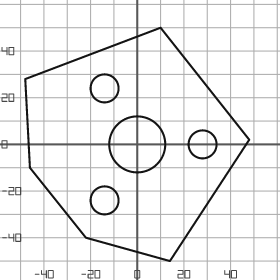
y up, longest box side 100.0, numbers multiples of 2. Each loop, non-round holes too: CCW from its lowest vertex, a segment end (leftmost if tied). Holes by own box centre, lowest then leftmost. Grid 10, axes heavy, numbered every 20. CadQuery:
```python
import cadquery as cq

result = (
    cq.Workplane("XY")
    .moveTo(14.0, -50.0)
    .lineTo(48.0, 2.0)
    .lineTo(10.0, 50.0)
    .lineTo(-48.0, 28.0)
    .lineTo(-46.0, -10.0)
    .lineTo(-22.0, -40.0)
    .close()
    .moveTo(-14.0, -24.0)
    .circle(6.0)
    .moveTo(0.0, 0.0)
    .circle(12.0)
    .moveTo(28.0, 0.0)
    .circle(6.0)
    .moveTo(-14.0, 24.0)
    .circle(6.0)
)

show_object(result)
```